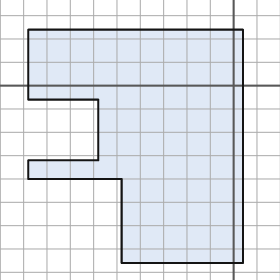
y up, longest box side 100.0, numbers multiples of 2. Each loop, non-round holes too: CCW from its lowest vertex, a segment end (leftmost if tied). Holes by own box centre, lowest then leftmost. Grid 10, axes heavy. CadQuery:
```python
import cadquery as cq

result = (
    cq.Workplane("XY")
    .moveTo(-48.0, -76.0)
    .lineTo(4.0, -76.0)
    .lineTo(4.0, 24.0)
    .lineTo(-88.0, 24.0)
    .lineTo(-88.0, -6.0)
    .lineTo(-58.0, -6.0)
    .lineTo(-58.0, -32.0)
    .lineTo(-88.0, -32.0)
    .lineTo(-88.0, -40.0)
    .lineTo(-48.0, -40.0)
    .close()
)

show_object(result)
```